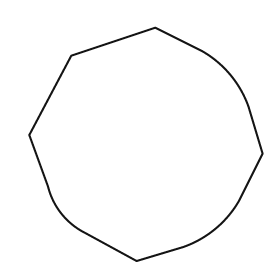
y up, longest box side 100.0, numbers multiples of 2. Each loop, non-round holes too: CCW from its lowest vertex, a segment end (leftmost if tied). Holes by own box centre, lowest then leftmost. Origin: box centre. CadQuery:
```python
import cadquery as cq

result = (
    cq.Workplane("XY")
    .moveTo(-4.0, -50.0)
    .lineTo(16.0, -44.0)
    .threePointArc((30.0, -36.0), (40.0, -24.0))
    .lineTo(50.0, -4.0)
    .lineTo(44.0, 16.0)
    .threePointArc((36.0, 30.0), (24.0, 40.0))
    .lineTo(4.0, 50.0)
    .lineTo(-32.0, 38.0)
    .lineTo(-50.0, 4.0)
    .lineTo(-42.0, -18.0)
    .threePointArc((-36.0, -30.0), (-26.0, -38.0))
    .close()
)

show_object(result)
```